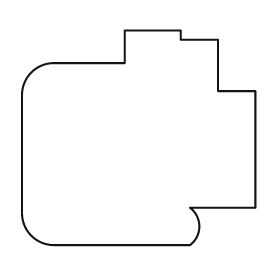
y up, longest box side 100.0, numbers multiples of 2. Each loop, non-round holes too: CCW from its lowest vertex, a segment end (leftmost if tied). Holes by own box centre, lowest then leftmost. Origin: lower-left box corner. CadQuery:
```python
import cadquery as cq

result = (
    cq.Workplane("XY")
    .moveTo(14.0, 0.0)
    .lineTo(72.0, 0.0)
    .threePointArc((76.0, 8.0), (72.0, 16.0))
    .lineTo(100.0, 16.0)
    .lineTo(100.0, 66.0)
    .lineTo(84.0, 66.0)
    .lineTo(84.0, 88.0)
    .lineTo(68.0, 88.0)
    .lineTo(68.0, 92.0)
    .lineTo(44.0, 92.0)
    .lineTo(44.0, 78.0)
    .lineTo(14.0, 78.0)
    .threePointArc((4.0, 74.0), (0.0, 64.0))
    .lineTo(0.0, 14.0)
    .threePointArc((4.0, 4.0), (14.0, 0.0))
    .close()
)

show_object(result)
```